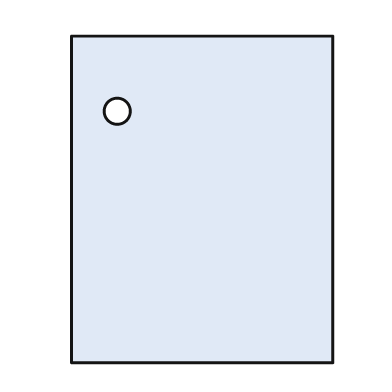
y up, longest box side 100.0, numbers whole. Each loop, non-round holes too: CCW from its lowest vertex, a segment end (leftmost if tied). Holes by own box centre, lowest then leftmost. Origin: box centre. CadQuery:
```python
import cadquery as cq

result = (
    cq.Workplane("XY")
    .moveTo(-40.0, -50.0)
    .lineTo(40.0, -50.0)
    .lineTo(40.0, 50.0)
    .lineTo(-40.0, 50.0)
    .close()
    .moveTo(-26.0, 27.0)
    .circle(4.0)
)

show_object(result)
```